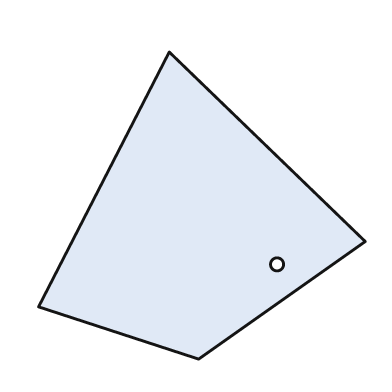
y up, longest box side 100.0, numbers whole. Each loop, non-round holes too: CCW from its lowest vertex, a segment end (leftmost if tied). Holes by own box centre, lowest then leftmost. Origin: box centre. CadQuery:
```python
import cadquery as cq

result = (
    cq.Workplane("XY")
    .moveTo(-1.0, -47.0)
    .lineTo(50.0, -11.0)
    .lineTo(-10.0, 47.0)
    .lineTo(-50.0, -31.0)
    .close()
    .moveTo(23.0, -18.0)
    .circle(2.0)
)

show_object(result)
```